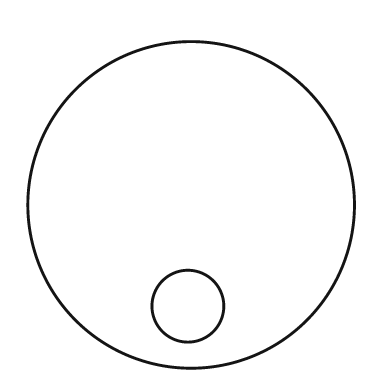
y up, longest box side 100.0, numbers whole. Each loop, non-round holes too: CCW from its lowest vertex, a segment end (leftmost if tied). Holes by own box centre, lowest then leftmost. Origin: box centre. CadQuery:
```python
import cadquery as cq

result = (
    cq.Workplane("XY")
    .moveTo(0.0, 0.0)
    .circle(50.0)
    .moveTo(-1.0, -31.0)
    .circle(11.0)
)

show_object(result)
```